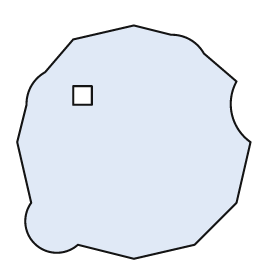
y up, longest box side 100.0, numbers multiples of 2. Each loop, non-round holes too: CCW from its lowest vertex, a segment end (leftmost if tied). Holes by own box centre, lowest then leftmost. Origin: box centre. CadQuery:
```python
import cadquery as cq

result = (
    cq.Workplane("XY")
    .moveTo(0.0, -50.0)
    .lineTo(26.0, -44.0)
    .lineTo(44.0, -26.0)
    .lineTo(50.0, 0.0)
    .threePointArc((42.0, 12.0), (44.0, 26.0))
    .lineTo(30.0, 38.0)
    .threePointArc((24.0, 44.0), (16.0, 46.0))
    .lineTo(0.0, 50.0)
    .lineTo(-26.0, 44.0)
    .lineTo(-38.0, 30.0)
    .threePointArc((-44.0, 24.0), (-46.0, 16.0))
    .lineTo(-50.0, 0.0)
    .lineTo(-44.0, -26.0)
    .threePointArc((-42.0, -44.0), (-24.0, -44.0))
    .close()
    .moveTo(-26.0, 16.0)
    .lineTo(-18.0, 16.0)
    .lineTo(-18.0, 24.0)
    .lineTo(-26.0, 24.0)
    .close()
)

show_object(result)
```